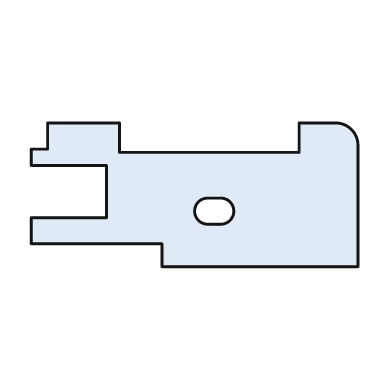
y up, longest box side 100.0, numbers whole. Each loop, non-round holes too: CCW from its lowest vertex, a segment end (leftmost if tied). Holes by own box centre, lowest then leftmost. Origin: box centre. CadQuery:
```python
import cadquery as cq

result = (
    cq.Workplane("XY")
    .moveTo(-10.0, -22.0)
    .lineTo(50.0, -22.0)
    .lineTo(50.0, 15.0)
    .threePointArc((48.0, 20.0), (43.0, 22.0))
    .lineTo(32.0, 22.0)
    .lineTo(32.0, 13.0)
    .lineTo(-23.0, 13.0)
    .lineTo(-23.0, 22.0)
    .lineTo(-45.0, 22.0)
    .lineTo(-45.0, 14.0)
    .lineTo(-50.0, 14.0)
    .lineTo(-50.0, 9.0)
    .lineTo(-27.0, 9.0)
    .lineTo(-27.0, -7.0)
    .lineTo(-50.0, -7.0)
    .lineTo(-50.0, -15.0)
    .lineTo(-10.0, -15.0)
    .close()
    .moveTo(4.0, -9.0)
    .lineTo(8.0, -9.0)
    .threePointArc((12.0, -5.0), (8.0, -1.0))
    .lineTo(4.0, -1.0)
    .threePointArc((0.0, -5.0), (4.0, -9.0))
    .close()
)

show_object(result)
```